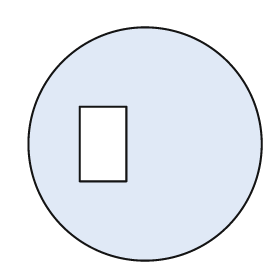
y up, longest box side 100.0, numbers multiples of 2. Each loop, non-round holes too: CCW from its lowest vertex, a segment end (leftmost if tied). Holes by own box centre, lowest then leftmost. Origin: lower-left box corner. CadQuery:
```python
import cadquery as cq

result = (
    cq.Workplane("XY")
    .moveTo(50.0, 50.0)
    .circle(50.0)
    .moveTo(22.0, 34.0)
    .lineTo(42.0, 34.0)
    .lineTo(42.0, 66.0)
    .lineTo(22.0, 66.0)
    .close()
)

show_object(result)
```